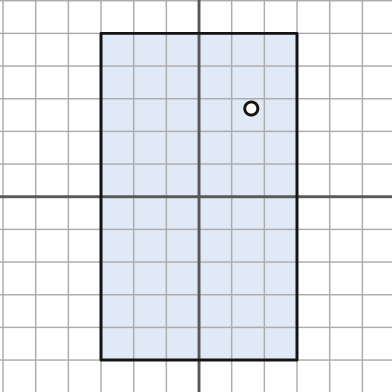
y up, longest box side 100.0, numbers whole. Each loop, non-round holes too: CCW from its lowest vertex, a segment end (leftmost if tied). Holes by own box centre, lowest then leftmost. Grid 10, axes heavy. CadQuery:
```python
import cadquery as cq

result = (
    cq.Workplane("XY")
    .moveTo(-30.0, -50.0)
    .lineTo(30.0, -50.0)
    .lineTo(30.0, 50.0)
    .lineTo(-30.0, 50.0)
    .close()
    .moveTo(16.0, 27.0)
    .circle(2.0)
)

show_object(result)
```